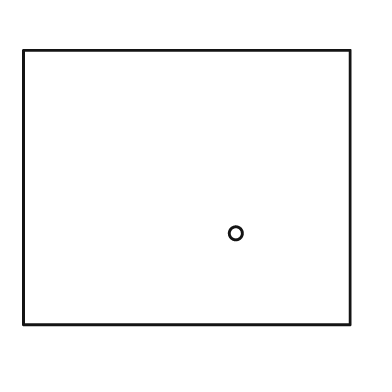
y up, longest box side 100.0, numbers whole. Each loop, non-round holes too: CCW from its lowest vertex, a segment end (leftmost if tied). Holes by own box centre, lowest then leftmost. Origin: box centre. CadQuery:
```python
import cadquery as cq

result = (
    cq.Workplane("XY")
    .moveTo(-50.0, -42.0)
    .lineTo(50.0, -42.0)
    .lineTo(50.0, 42.0)
    .lineTo(-50.0, 42.0)
    .close()
    .moveTo(15.0, -14.0)
    .circle(2.0)
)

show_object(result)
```